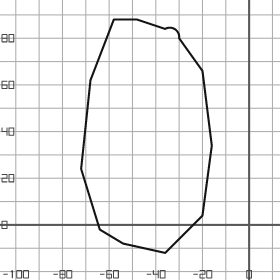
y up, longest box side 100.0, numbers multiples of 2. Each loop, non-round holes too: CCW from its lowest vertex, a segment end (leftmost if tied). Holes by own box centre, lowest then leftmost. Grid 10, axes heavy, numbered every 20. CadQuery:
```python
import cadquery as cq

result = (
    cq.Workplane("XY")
    .moveTo(-36.0, -12.0)
    .lineTo(-20.0, 4.0)
    .lineTo(-16.0, 34.0)
    .lineTo(-20.0, 66.0)
    .lineTo(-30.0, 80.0)
    .threePointArc((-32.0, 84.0), (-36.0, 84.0))
    .lineTo(-48.0, 88.0)
    .lineTo(-58.0, 88.0)
    .lineTo(-68.0, 62.0)
    .lineTo(-72.0, 24.0)
    .lineTo(-64.0, -2.0)
    .lineTo(-54.0, -8.0)
    .close()
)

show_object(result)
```